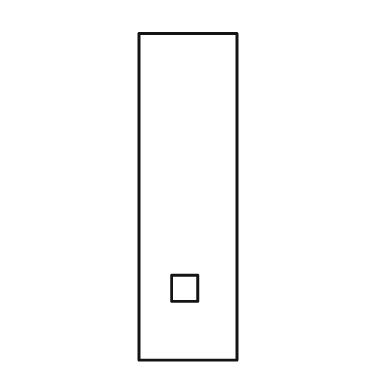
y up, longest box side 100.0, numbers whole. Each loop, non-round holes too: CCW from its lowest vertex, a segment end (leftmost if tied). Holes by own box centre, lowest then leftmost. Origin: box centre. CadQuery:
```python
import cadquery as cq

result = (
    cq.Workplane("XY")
    .moveTo(-15.0, -50.0)
    .lineTo(15.0, -50.0)
    .lineTo(15.0, 50.0)
    .lineTo(-15.0, 50.0)
    .close()
    .moveTo(-5.0, -32.0)
    .lineTo(3.0, -32.0)
    .lineTo(3.0, -24.0)
    .lineTo(-5.0, -24.0)
    .close()
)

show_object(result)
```